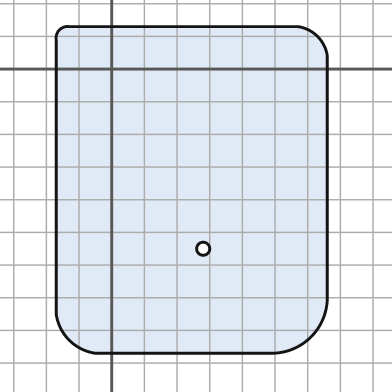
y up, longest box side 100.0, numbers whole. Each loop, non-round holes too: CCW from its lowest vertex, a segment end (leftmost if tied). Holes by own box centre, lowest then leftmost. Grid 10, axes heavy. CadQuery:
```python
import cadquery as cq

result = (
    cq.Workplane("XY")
    .moveTo(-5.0, -87.0)
    .lineTo(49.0, -87.0)
    .threePointArc((61.0, -82.0), (66.0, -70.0))
    .lineTo(66.0, 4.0)
    .threePointArc((63.0, 10.0), (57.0, 13.0))
    .lineTo(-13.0, 13.0)
    .threePointArc((-16.0, 12.0), (-17.0, 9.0))
    .lineTo(-17.0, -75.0)
    .threePointArc((-13.0, -83.0), (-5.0, -87.0))
    .close()
    .moveTo(28.0, -55.0)
    .circle(2.0)
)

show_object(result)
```